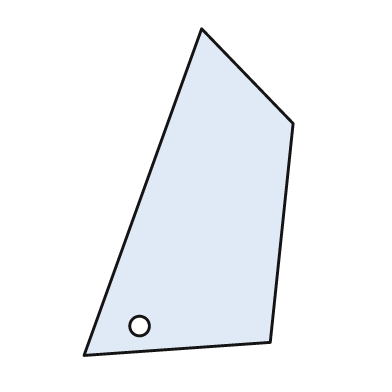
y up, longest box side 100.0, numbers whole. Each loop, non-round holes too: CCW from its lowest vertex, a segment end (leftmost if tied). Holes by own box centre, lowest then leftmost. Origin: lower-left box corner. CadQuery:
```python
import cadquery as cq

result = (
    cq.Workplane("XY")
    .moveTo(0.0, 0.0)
    .lineTo(57.0, 4.0)
    .lineTo(64.0, 71.0)
    .lineTo(36.0, 100.0)
    .close()
    .moveTo(17.0, 9.0)
    .circle(3.0)
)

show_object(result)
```